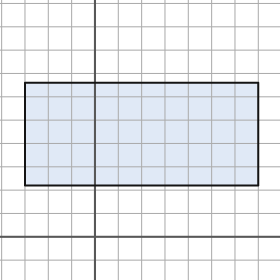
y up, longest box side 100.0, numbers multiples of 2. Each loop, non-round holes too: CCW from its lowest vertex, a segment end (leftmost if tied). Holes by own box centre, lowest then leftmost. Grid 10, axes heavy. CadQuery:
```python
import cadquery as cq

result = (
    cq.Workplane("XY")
    .moveTo(-30.0, 22.0)
    .lineTo(70.0, 22.0)
    .lineTo(70.0, 66.0)
    .lineTo(-30.0, 66.0)
    .close()
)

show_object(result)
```